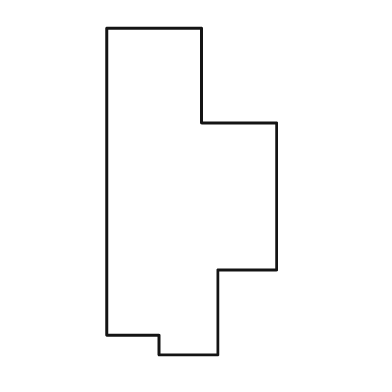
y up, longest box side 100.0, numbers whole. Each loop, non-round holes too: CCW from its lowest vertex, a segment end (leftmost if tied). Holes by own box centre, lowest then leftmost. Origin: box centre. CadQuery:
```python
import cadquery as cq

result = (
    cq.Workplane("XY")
    .moveTo(-10.0, -50.0)
    .lineTo(8.0, -50.0)
    .lineTo(8.0, -24.0)
    .lineTo(26.0, -24.0)
    .lineTo(26.0, 21.0)
    .lineTo(3.0, 21.0)
    .lineTo(3.0, 50.0)
    .lineTo(-26.0, 50.0)
    .lineTo(-26.0, -44.0)
    .lineTo(-10.0, -44.0)
    .close()
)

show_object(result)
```